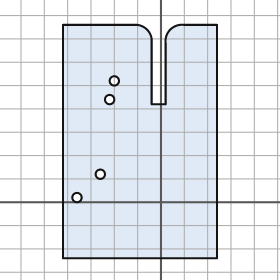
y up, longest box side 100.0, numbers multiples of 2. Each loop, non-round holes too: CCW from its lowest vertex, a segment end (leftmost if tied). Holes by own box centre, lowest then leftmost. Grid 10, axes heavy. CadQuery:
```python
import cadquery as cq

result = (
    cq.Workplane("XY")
    .moveTo(-42.0, -24.0)
    .lineTo(24.0, -24.0)
    .lineTo(24.0, 76.0)
    .lineTo(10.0, 76.0)
    .threePointArc((4.0, 74.0), (2.0, 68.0))
    .lineTo(2.0, 42.0)
    .lineTo(-4.0, 42.0)
    .lineTo(-4.0, 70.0)
    .threePointArc((-6.0, 74.0), (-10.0, 76.0))
    .lineTo(-42.0, 76.0)
    .close()
    .moveTo(-36.0, 2.0)
    .circle(2.0)
    .moveTo(-26.0, 12.0)
    .circle(2.0)
    .moveTo(-22.0, 44.0)
    .circle(2.0)
    .moveTo(-20.0, 52.0)
    .circle(2.0)
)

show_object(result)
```